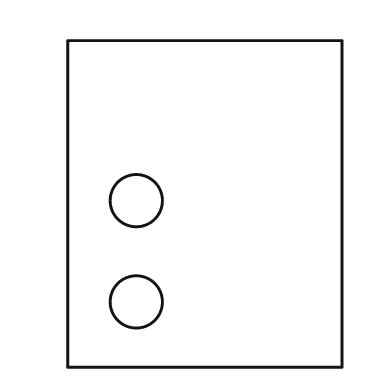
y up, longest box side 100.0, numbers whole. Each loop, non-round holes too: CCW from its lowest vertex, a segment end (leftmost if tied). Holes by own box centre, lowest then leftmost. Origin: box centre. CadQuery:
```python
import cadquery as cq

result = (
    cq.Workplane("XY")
    .moveTo(-42.0, -50.0)
    .lineTo(42.0, -50.0)
    .lineTo(42.0, 50.0)
    .lineTo(-42.0, 50.0)
    .close()
    .moveTo(-21.0, -30.0)
    .circle(8.0)
    .moveTo(-21.0, 1.0)
    .circle(8.0)
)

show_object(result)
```